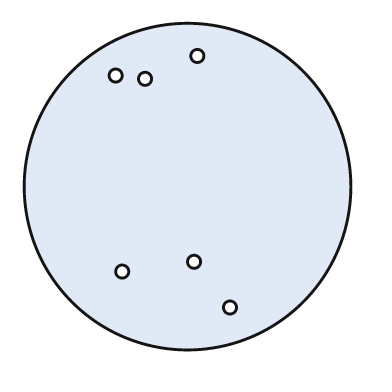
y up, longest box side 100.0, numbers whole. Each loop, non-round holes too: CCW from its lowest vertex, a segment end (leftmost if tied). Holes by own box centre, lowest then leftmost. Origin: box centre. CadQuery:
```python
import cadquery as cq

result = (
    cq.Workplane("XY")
    .moveTo(0.0, 0.0)
    .circle(50.0)
    .moveTo(13.0, -37.0)
    .circle(2.0)
    .moveTo(-20.0, -26.0)
    .circle(2.0)
    .moveTo(2.0, -23.0)
    .circle(2.0)
    .moveTo(-13.0, 33.0)
    .circle(2.0)
    .moveTo(-22.0, 34.0)
    .circle(2.0)
    .moveTo(3.0, 40.0)
    .circle(2.0)
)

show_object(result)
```